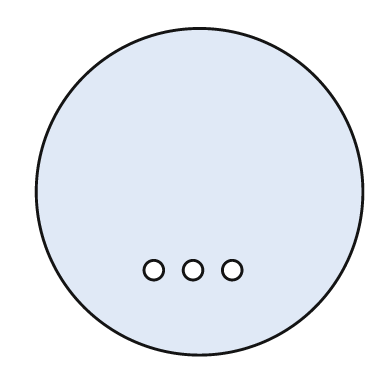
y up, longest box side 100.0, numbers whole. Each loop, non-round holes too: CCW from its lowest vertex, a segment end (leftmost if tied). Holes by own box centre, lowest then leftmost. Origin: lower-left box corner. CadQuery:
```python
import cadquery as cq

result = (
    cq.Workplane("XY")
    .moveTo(50.0, 50.0)
    .circle(50.0)
    .moveTo(36.0, 26.0)
    .circle(3.0)
    .moveTo(48.0, 26.0)
    .circle(3.0)
    .moveTo(60.0, 26.0)
    .circle(3.0)
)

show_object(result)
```